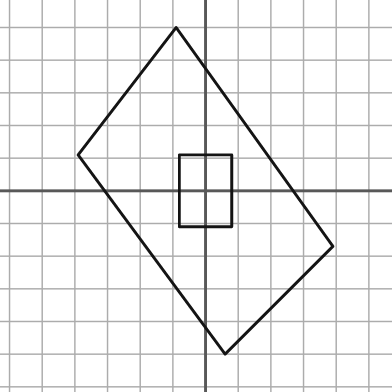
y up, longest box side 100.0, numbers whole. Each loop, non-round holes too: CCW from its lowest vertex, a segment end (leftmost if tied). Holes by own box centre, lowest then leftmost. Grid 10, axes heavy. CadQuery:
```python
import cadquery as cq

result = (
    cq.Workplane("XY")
    .moveTo(6.0, -50.0)
    .lineTo(39.0, -17.0)
    .lineTo(-9.0, 50.0)
    .lineTo(-39.0, 11.0)
    .close()
    .moveTo(-8.0, -11.0)
    .lineTo(8.0, -11.0)
    .lineTo(8.0, 11.0)
    .lineTo(-8.0, 11.0)
    .close()
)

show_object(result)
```